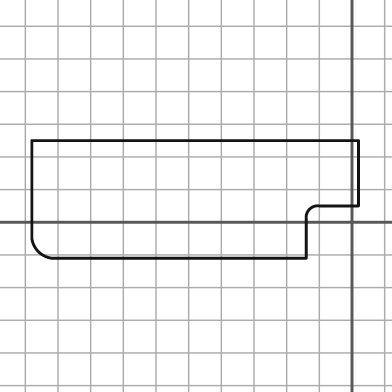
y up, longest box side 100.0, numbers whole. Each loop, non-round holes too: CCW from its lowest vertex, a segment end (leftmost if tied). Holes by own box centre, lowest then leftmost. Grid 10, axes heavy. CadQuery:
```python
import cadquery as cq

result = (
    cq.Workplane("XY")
    .moveTo(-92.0, -11.0)
    .lineTo(-14.0, -11.0)
    .lineTo(-14.0, 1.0)
    .threePointArc((-13.0, 4.0), (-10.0, 5.0))
    .lineTo(2.0, 5.0)
    .lineTo(2.0, 25.0)
    .lineTo(-98.0, 25.0)
    .lineTo(-98.0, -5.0)
    .threePointArc((-96.0, -9.0), (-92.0, -11.0))
    .close()
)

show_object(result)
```